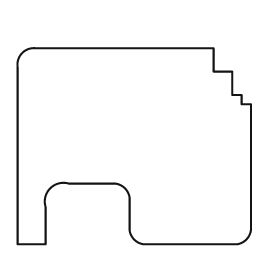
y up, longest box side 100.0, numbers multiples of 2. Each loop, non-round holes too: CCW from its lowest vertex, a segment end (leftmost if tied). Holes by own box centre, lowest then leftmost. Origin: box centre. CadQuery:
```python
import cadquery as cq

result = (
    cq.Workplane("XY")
    .moveTo(-50.0, -42.0)
    .lineTo(-38.0, -42.0)
    .lineTo(-38.0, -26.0)
    .threePointArc((-36.0, -18.0), (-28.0, -16.0))
    .lineTo(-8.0, -16.0)
    .threePointArc((-4.0, -18.0), (-2.0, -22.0))
    .lineTo(-2.0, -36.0)
    .threePointArc((0.0, -40.0), (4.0, -42.0))
    .lineTo(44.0, -42.0)
    .threePointArc((48.0, -40.0), (50.0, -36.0))
    .lineTo(50.0, 18.0)
    .lineTo(46.0, 18.0)
    .lineTo(46.0, 22.0)
    .lineTo(42.0, 22.0)
    .lineTo(42.0, 32.0)
    .lineTo(34.0, 32.0)
    .lineTo(34.0, 42.0)
    .lineTo(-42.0, 42.0)
    .threePointArc((-48.0, 40.0), (-50.0, 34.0))
    .close()
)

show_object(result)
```